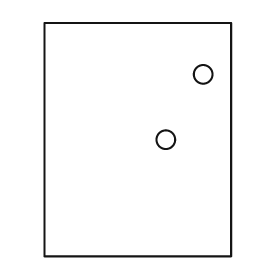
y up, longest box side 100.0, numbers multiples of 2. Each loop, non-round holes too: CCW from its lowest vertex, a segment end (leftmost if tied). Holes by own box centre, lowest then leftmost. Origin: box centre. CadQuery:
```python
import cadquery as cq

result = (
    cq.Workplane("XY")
    .moveTo(-40.0, -50.0)
    .lineTo(40.0, -50.0)
    .lineTo(40.0, 50.0)
    .lineTo(-40.0, 50.0)
    .close()
    .moveTo(12.0, 0.0)
    .circle(4.0)
    .moveTo(28.0, 28.0)
    .circle(4.0)
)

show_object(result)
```